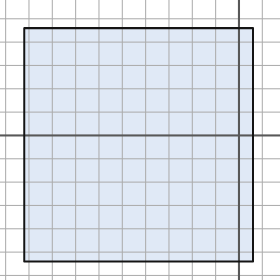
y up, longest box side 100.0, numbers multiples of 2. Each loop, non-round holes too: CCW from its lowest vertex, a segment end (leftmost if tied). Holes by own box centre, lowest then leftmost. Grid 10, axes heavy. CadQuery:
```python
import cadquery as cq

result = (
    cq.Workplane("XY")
    .moveTo(-92.0, -54.0)
    .lineTo(6.0, -54.0)
    .lineTo(6.0, 46.0)
    .lineTo(-92.0, 46.0)
    .close()
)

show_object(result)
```